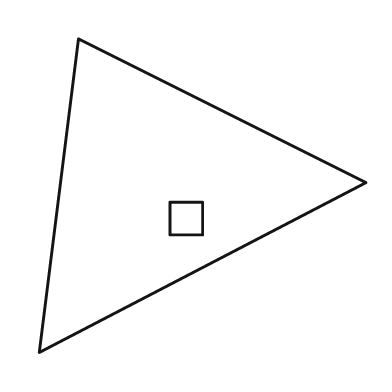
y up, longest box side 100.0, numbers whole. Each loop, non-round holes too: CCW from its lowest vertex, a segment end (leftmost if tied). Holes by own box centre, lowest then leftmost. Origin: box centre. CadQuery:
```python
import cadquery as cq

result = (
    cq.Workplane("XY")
    .moveTo(-50.0, -48.0)
    .lineTo(50.0, 4.0)
    .lineTo(-38.0, 48.0)
    .close()
    .moveTo(-10.0, -12.0)
    .lineTo(0.0, -12.0)
    .lineTo(0.0, -2.0)
    .lineTo(-10.0, -2.0)
    .close()
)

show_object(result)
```